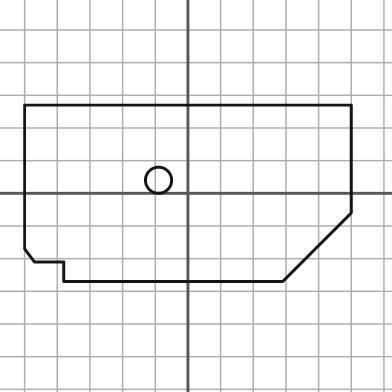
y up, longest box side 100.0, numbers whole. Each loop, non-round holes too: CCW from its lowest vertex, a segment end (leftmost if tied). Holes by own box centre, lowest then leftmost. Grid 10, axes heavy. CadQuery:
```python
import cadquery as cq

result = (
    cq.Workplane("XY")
    .moveTo(-38.0, -27.0)
    .lineTo(29.0, -27.0)
    .lineTo(50.0, -6.0)
    .lineTo(50.0, 27.0)
    .lineTo(-50.0, 27.0)
    .lineTo(-50.0, -17.0)
    .lineTo(-47.0, -21.0)
    .lineTo(-38.0, -21.0)
    .close()
    .moveTo(-9.0, 4.0)
    .circle(4.0)
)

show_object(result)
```